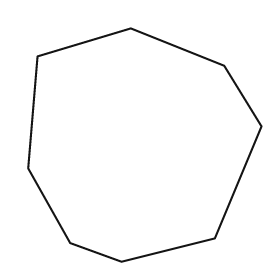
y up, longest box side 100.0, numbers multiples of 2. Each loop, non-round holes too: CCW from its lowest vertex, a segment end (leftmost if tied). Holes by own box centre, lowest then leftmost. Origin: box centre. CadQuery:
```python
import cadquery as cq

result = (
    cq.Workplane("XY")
    .moveTo(-10.0, -50.0)
    .lineTo(30.0, -40.0)
    .lineTo(50.0, 8.0)
    .lineTo(34.0, 34.0)
    .lineTo(-6.0, 50.0)
    .lineTo(-46.0, 38.0)
    .lineTo(-50.0, -10.0)
    .lineTo(-32.0, -42.0)
    .close()
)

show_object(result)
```